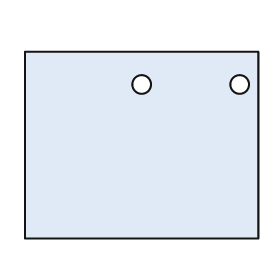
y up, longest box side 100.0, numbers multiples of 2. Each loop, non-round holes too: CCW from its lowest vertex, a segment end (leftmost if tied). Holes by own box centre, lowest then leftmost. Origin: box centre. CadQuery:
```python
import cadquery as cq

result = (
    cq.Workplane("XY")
    .moveTo(-50.0, -40.0)
    .lineTo(50.0, -40.0)
    .lineTo(50.0, 40.0)
    .lineTo(-50.0, 40.0)
    .close()
    .moveTo(0.0, 26.0)
    .circle(4.0)
    .moveTo(42.0, 26.0)
    .circle(4.0)
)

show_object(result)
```